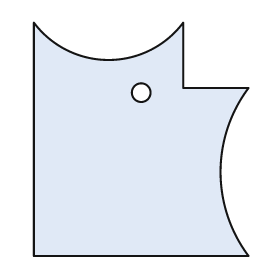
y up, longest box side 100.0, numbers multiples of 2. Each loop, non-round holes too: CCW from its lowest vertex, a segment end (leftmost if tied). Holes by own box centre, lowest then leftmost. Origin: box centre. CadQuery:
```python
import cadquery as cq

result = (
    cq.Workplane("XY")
    .moveTo(-46.0, -50.0)
    .lineTo(46.0, -50.0)
    .threePointArc((34.0, -14.0), (46.0, 22.0))
    .lineTo(18.0, 22.0)
    .lineTo(18.0, 50.0)
    .threePointArc((-14.0, 34.0), (-46.0, 50.0))
    .close()
    .moveTo(0.0, 20.0)
    .circle(4.0)
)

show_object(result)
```